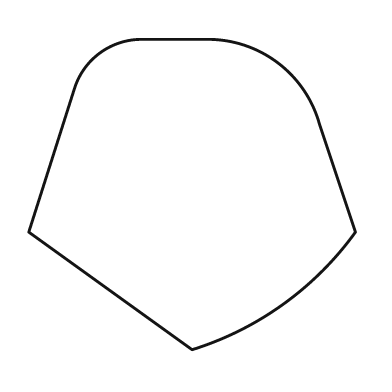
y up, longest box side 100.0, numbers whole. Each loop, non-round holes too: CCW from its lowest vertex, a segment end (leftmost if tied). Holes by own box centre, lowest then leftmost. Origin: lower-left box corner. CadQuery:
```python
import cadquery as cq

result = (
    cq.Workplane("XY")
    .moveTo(50.0, 0.0)
    .threePointArc((78.0, 14.0), (100.0, 36.0))
    .lineTo(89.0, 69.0)
    .threePointArc((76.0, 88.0), (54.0, 95.0))
    .lineTo(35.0, 95.0)
    .threePointArc((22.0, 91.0), (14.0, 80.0))
    .lineTo(0.0, 36.0)
    .close()
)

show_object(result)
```